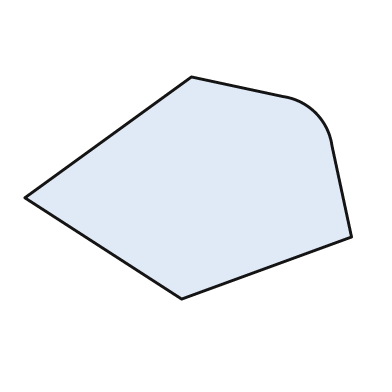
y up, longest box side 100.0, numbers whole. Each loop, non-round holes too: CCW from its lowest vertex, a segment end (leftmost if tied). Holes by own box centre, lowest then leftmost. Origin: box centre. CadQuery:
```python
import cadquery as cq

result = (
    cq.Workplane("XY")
    .moveTo(-2.0, -34.0)
    .lineTo(50.0, -15.0)
    .lineTo(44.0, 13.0)
    .threePointArc((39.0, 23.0), (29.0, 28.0))
    .lineTo(1.0, 34.0)
    .lineTo(-50.0, -3.0)
    .close()
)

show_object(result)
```